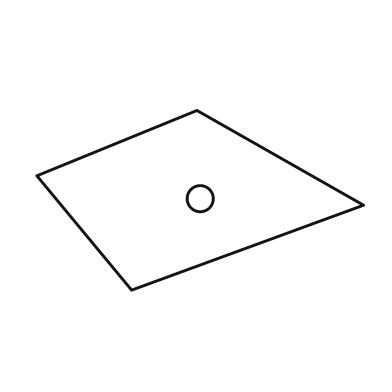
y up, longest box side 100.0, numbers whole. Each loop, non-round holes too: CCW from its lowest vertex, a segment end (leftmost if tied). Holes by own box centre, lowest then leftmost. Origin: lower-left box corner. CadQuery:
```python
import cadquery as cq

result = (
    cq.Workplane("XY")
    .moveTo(29.0, 0.0)
    .lineTo(100.0, 26.0)
    .lineTo(49.0, 55.0)
    .lineTo(0.0, 35.0)
    .close()
    .moveTo(50.0, 28.0)
    .circle(4.0)
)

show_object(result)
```